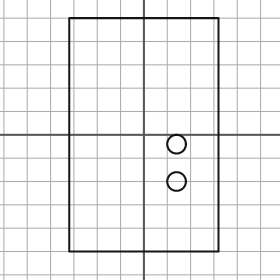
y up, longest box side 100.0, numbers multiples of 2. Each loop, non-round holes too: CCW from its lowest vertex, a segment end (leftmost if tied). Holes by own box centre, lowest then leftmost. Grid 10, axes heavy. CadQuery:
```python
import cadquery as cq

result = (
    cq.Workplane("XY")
    .moveTo(-32.0, -50.0)
    .lineTo(32.0, -50.0)
    .lineTo(32.0, 50.0)
    .lineTo(-32.0, 50.0)
    .close()
    .moveTo(14.0, -20.0)
    .circle(4.0)
    .moveTo(14.0, -4.0)
    .circle(4.0)
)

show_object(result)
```